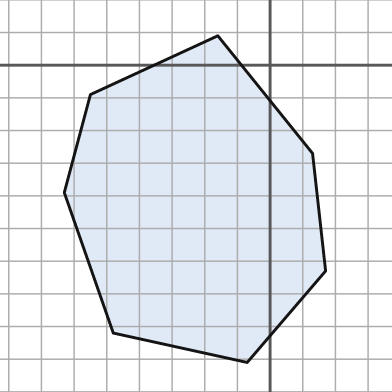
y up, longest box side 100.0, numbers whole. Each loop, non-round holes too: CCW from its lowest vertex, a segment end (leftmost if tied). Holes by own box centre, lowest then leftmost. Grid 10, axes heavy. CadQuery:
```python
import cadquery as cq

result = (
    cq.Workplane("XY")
    .moveTo(-7.0, -91.0)
    .lineTo(17.0, -63.0)
    .lineTo(13.0, -27.0)
    .lineTo(-16.0, 9.0)
    .lineTo(-55.0, -9.0)
    .lineTo(-63.0, -39.0)
    .lineTo(-48.0, -82.0)
    .close()
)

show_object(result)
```